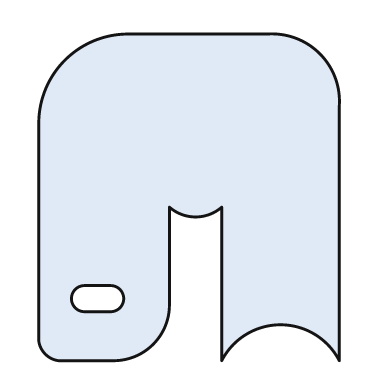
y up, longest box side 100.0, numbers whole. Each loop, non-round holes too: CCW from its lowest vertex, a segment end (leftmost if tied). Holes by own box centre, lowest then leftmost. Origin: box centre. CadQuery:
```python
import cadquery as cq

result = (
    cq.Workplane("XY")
    .moveTo(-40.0, -50.0)
    .lineTo(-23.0, -50.0)
    .threePointArc((-11.0, -45.0), (-6.0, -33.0))
    .lineTo(-6.0, -3.0)
    .threePointArc((2.0, -6.0), (10.0, -3.0))
    .lineTo(10.0, -50.0)
    .threePointArc((28.0, -39.0), (46.0, -50.0))
    .lineTo(46.0, 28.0)
    .threePointArc((40.0, 44.0), (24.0, 50.0))
    .lineTo(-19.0, 50.0)
    .threePointArc((-38.0, 42.0), (-46.0, 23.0))
    .lineTo(-46.0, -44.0)
    .threePointArc((-44.0, -48.0), (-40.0, -50.0))
    .close()
    .moveTo(-32.0, -35.0)
    .lineTo(-24.0, -35.0)
    .threePointArc((-20.0, -31.0), (-24.0, -27.0))
    .lineTo(-32.0, -27.0)
    .threePointArc((-36.0, -31.0), (-32.0, -35.0))
    .close()
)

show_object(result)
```